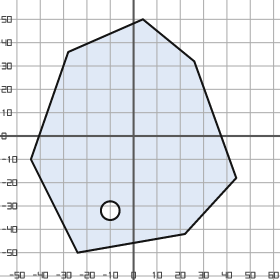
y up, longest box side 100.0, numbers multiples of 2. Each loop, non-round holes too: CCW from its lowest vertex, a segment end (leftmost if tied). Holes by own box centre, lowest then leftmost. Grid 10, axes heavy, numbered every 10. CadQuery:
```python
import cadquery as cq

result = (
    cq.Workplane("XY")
    .moveTo(-24.0, -50.0)
    .lineTo(22.0, -42.0)
    .lineTo(44.0, -18.0)
    .lineTo(26.0, 32.0)
    .lineTo(4.0, 50.0)
    .lineTo(-28.0, 36.0)
    .lineTo(-44.0, -10.0)
    .close()
    .moveTo(-10.0, -32.0)
    .circle(4.0)
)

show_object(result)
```